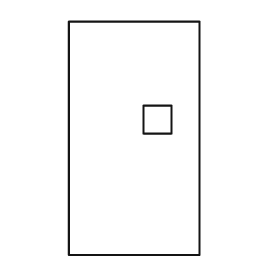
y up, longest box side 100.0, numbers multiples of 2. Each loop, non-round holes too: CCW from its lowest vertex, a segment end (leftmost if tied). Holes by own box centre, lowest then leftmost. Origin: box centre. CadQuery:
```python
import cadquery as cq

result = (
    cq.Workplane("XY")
    .moveTo(-28.0, -50.0)
    .lineTo(28.0, -50.0)
    .lineTo(28.0, 50.0)
    .lineTo(-28.0, 50.0)
    .close()
    .moveTo(4.0, 2.0)
    .lineTo(16.0, 2.0)
    .lineTo(16.0, 14.0)
    .lineTo(4.0, 14.0)
    .close()
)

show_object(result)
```